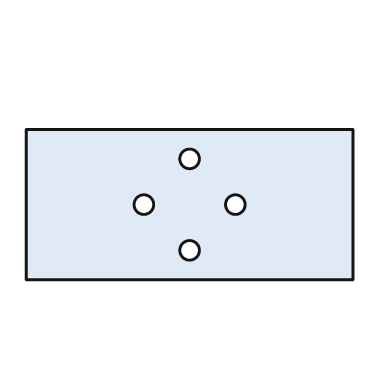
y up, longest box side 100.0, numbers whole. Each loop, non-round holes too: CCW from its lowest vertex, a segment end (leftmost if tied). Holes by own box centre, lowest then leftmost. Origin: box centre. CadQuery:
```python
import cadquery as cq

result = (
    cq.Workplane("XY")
    .moveTo(-50.0, -23.0)
    .lineTo(50.0, -23.0)
    .lineTo(50.0, 23.0)
    .lineTo(-50.0, 23.0)
    .close()
    .moveTo(0.0, -14.0)
    .circle(3.0)
    .moveTo(-14.0, 0.0)
    .circle(3.0)
    .moveTo(14.0, 0.0)
    .circle(3.0)
    .moveTo(0.0, 14.0)
    .circle(3.0)
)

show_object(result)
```